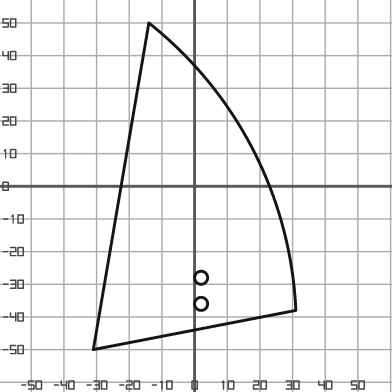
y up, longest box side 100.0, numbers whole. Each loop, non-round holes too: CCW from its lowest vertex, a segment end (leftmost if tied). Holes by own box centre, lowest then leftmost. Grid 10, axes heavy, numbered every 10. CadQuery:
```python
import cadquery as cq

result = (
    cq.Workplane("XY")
    .moveTo(-31.0, -50.0)
    .lineTo(31.0, -38.0)
    .threePointArc((18.0, 11.0), (-14.0, 50.0))
    .close()
    .moveTo(2.0, -36.0)
    .circle(2.0)
    .moveTo(2.0, -28.0)
    .circle(2.0)
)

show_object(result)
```